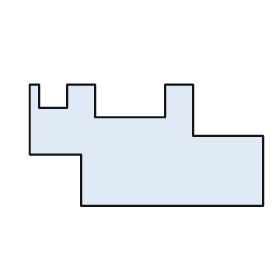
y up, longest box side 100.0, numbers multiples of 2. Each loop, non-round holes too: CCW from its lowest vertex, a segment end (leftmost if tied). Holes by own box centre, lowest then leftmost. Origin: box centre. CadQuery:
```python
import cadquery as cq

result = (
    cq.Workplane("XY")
    .moveTo(-28.0, -26.0)
    .lineTo(50.0, -26.0)
    .lineTo(50.0, 4.0)
    .lineTo(20.0, 4.0)
    .lineTo(20.0, 26.0)
    .lineTo(8.0, 26.0)
    .lineTo(8.0, 12.0)
    .lineTo(-22.0, 12.0)
    .lineTo(-22.0, 26.0)
    .lineTo(-34.0, 26.0)
    .lineTo(-34.0, 16.0)
    .lineTo(-46.0, 16.0)
    .lineTo(-46.0, 26.0)
    .lineTo(-50.0, 26.0)
    .lineTo(-50.0, -4.0)
    .lineTo(-28.0, -4.0)
    .close()
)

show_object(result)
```